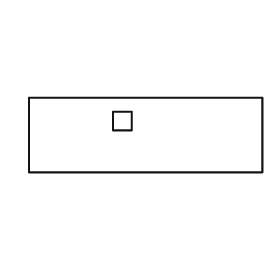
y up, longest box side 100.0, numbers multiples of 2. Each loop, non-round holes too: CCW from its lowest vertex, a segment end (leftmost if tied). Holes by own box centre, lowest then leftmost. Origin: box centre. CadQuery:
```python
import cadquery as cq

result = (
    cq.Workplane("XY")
    .moveTo(-50.0, -16.0)
    .lineTo(50.0, -16.0)
    .lineTo(50.0, 16.0)
    .lineTo(-50.0, 16.0)
    .close()
    .moveTo(-14.0, 2.0)
    .lineTo(-6.0, 2.0)
    .lineTo(-6.0, 10.0)
    .lineTo(-14.0, 10.0)
    .close()
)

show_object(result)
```